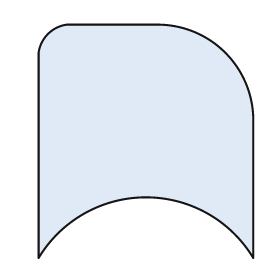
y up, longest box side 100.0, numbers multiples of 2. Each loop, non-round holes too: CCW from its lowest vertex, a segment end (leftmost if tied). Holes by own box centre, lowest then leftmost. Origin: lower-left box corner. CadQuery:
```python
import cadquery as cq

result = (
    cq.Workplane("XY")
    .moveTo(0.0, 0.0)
    .threePointArc((46.0, 26.0), (92.0, 0.0))
    .lineTo(92.0, 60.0)
    .threePointArc((80.0, 88.0), (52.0, 100.0))
    .lineTo(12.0, 100.0)
    .threePointArc((4.0, 96.0), (0.0, 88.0))
    .close()
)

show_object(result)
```